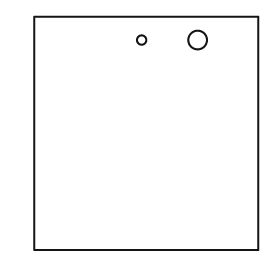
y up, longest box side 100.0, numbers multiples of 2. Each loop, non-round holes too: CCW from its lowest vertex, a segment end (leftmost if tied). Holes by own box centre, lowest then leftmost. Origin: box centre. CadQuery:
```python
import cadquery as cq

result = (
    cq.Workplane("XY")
    .moveTo(-48.0, -50.0)
    .lineTo(48.0, -50.0)
    .lineTo(48.0, 50.0)
    .lineTo(-48.0, 50.0)
    .close()
    .moveTo(-2.0, 40.0)
    .circle(2.0)
    .moveTo(22.0, 40.0)
    .circle(4.0)
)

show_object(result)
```